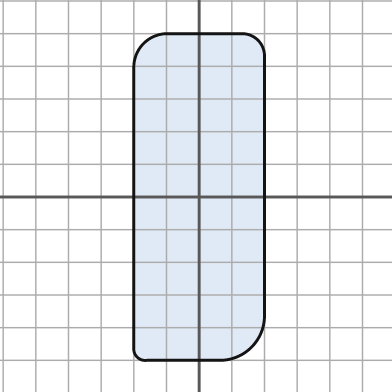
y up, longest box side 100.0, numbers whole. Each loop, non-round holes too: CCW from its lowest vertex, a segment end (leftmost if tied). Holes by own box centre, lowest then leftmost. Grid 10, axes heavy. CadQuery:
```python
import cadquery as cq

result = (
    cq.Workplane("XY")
    .moveTo(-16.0, -50.0)
    .lineTo(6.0, -50.0)
    .threePointArc((16.0, -46.0), (20.0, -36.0))
    .lineTo(20.0, 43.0)
    .threePointArc((18.0, 48.0), (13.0, 50.0))
    .lineTo(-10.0, 50.0)
    .threePointArc((-17.0, 47.0), (-20.0, 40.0))
    .lineTo(-20.0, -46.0)
    .threePointArc((-19.0, -49.0), (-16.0, -50.0))
    .close()
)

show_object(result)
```